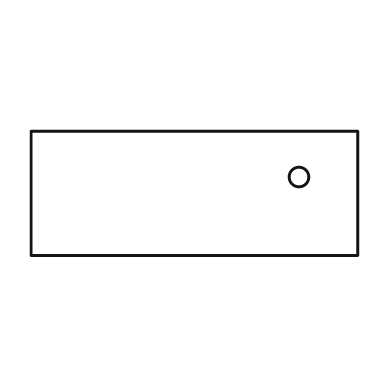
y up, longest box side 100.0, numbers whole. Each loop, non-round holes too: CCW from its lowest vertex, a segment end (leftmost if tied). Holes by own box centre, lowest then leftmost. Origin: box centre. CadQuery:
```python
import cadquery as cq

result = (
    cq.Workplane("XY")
    .moveTo(-50.0, -19.0)
    .lineTo(50.0, -19.0)
    .lineTo(50.0, 19.0)
    .lineTo(-50.0, 19.0)
    .close()
    .moveTo(32.0, 5.0)
    .circle(3.0)
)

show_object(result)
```